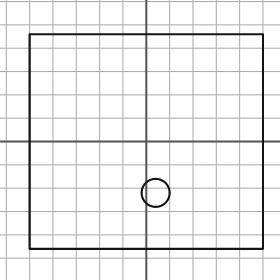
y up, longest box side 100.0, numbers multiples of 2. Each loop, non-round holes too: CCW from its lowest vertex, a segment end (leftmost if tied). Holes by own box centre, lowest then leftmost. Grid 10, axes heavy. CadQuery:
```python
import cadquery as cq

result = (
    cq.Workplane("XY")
    .moveTo(-50.0, -46.0)
    .lineTo(50.0, -46.0)
    .lineTo(50.0, 46.0)
    .lineTo(-50.0, 46.0)
    .close()
    .moveTo(4.0, -22.0)
    .circle(6.0)
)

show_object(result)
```